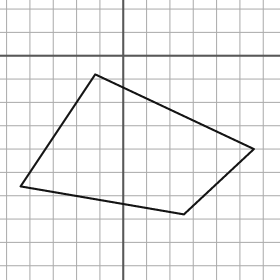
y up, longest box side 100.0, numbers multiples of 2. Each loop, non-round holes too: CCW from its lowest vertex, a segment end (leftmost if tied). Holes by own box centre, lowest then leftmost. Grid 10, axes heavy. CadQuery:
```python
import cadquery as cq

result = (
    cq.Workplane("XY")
    .moveTo(26.0, -68.0)
    .lineTo(56.0, -40.0)
    .lineTo(-12.0, -8.0)
    .lineTo(-44.0, -56.0)
    .close()
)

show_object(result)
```